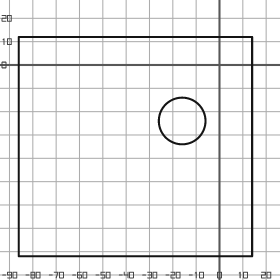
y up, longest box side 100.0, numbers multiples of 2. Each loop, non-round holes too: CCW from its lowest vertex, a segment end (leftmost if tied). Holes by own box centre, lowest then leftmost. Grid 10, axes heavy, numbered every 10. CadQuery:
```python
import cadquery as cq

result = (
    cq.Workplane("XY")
    .moveTo(-86.0, -82.0)
    .lineTo(14.0, -82.0)
    .lineTo(14.0, 12.0)
    .lineTo(-86.0, 12.0)
    .close()
    .moveTo(-16.0, -24.0)
    .circle(10.0)
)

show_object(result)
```